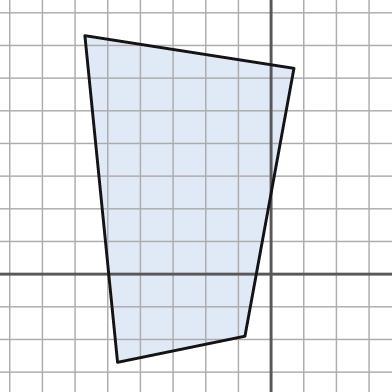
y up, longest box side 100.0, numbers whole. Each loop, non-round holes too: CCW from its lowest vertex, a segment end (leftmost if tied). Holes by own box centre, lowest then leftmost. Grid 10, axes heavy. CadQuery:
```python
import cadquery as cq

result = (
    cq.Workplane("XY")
    .moveTo(-47.0, -27.0)
    .lineTo(-8.0, -19.0)
    .lineTo(7.0, 63.0)
    .lineTo(-57.0, 73.0)
    .close()
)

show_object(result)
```